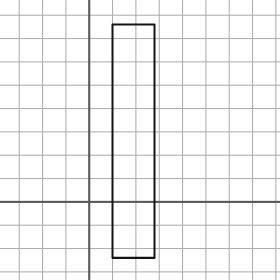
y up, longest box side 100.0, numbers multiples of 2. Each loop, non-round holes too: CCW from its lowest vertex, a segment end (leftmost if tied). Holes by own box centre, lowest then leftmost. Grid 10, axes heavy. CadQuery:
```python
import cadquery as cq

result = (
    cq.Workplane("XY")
    .moveTo(10.0, -24.0)
    .lineTo(28.0, -24.0)
    .lineTo(28.0, 76.0)
    .lineTo(10.0, 76.0)
    .close()
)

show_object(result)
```